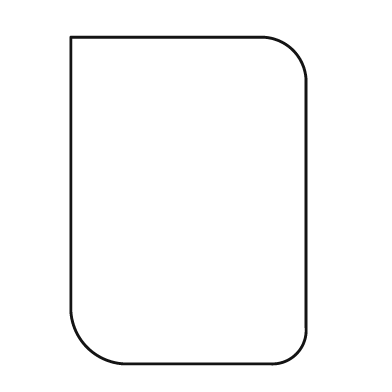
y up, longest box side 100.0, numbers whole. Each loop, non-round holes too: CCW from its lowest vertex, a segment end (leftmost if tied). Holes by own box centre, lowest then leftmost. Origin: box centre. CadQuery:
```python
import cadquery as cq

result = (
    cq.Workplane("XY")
    .moveTo(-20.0, -50.0)
    .lineTo(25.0, -50.0)
    .threePointArc((33.0, -47.0), (36.0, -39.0))
    .lineTo(36.0, 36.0)
    .threePointArc((32.0, 46.0), (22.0, 50.0))
    .lineTo(-36.0, 50.0)
    .lineTo(-36.0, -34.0)
    .threePointArc((-31.0, -45.0), (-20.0, -50.0))
    .close()
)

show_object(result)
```